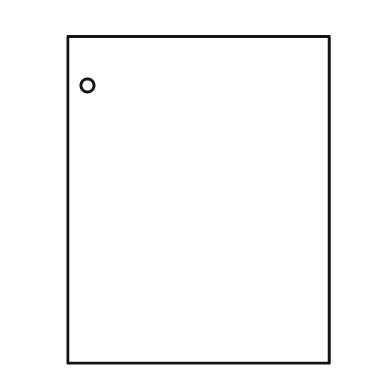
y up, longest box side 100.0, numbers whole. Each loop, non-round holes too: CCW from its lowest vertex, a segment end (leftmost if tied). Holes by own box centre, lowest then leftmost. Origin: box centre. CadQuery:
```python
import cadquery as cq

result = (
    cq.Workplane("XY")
    .moveTo(-40.0, -50.0)
    .lineTo(40.0, -50.0)
    .lineTo(40.0, 50.0)
    .lineTo(-40.0, 50.0)
    .close()
    .moveTo(-34.0, 35.0)
    .circle(2.0)
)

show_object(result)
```